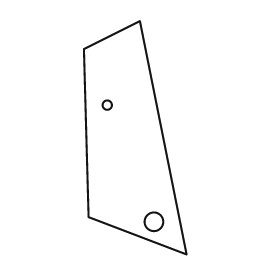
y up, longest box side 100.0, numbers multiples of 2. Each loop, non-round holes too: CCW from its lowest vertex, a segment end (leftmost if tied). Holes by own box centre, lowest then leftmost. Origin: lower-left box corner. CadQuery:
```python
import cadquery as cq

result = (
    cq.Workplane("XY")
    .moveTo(44.0, 0.0)
    .lineTo(24.0, 100.0)
    .lineTo(0.0, 88.0)
    .lineTo(2.0, 16.0)
    .close()
    .moveTo(30.0, 14.0)
    .circle(4.0)
    .moveTo(10.0, 64.0)
    .circle(2.0)
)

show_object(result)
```